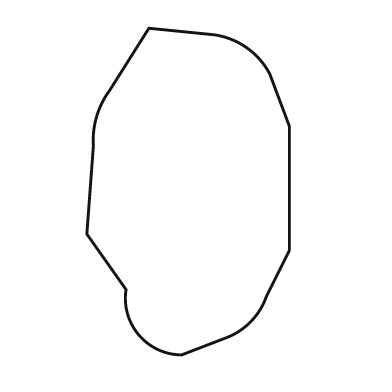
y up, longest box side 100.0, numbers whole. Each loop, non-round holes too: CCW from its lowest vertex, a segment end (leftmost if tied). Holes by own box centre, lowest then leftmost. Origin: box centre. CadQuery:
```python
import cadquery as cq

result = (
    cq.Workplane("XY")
    .moveTo(-2.0, -50.0)
    .lineTo(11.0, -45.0)
    .threePointArc((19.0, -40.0), (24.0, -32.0))
    .lineTo(31.0, -18.0)
    .lineTo(31.0, 20.0)
    .lineTo(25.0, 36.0)
    .threePointArc((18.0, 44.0), (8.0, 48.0))
    .lineTo(-12.0, 50.0)
    .lineTo(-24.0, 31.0)
    .threePointArc((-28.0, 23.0), (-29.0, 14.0))
    .lineTo(-31.0, -13.0)
    .lineTo(-19.0, -30.0)
    .threePointArc((-15.0, -44.0), (-2.0, -50.0))
    .close()
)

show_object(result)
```